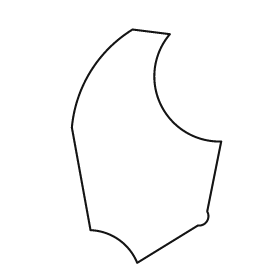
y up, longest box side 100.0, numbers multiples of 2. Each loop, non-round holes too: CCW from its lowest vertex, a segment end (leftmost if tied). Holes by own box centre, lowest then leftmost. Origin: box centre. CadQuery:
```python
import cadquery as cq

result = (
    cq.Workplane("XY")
    .moveTo(-4.0, -50.0)
    .lineTo(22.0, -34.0)
    .threePointArc((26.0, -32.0), (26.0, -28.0))
    .lineTo(32.0, 2.0)
    .threePointArc((6.0, 18.0), (10.0, 48.0))
    .lineTo(-6.0, 50.0)
    .threePointArc((-24.0, 32.0), (-32.0, 8.0))
    .lineTo(-24.0, -36.0)
    .threePointArc((-12.0, -40.0), (-4.0, -50.0))
    .close()
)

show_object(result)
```